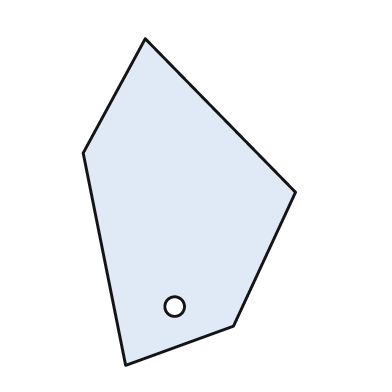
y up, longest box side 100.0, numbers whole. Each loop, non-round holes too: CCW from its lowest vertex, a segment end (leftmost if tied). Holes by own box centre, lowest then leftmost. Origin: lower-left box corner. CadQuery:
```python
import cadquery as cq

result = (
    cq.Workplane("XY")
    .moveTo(13.0, 0.0)
    .lineTo(46.0, 12.0)
    .lineTo(65.0, 53.0)
    .lineTo(19.0, 100.0)
    .lineTo(0.0, 65.0)
    .close()
    .moveTo(28.0, 18.0)
    .circle(3.0)
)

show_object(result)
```